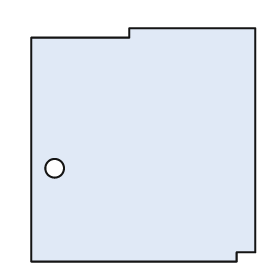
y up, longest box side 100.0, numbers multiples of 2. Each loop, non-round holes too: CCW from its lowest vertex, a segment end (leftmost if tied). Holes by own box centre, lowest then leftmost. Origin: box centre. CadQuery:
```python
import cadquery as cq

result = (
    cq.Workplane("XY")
    .moveTo(-48.0, -50.0)
    .lineTo(40.0, -50.0)
    .lineTo(40.0, -46.0)
    .lineTo(48.0, -46.0)
    .lineTo(48.0, 50.0)
    .lineTo(-6.0, 50.0)
    .lineTo(-6.0, 46.0)
    .lineTo(-48.0, 46.0)
    .close()
    .moveTo(-38.0, -10.0)
    .circle(4.0)
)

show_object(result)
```